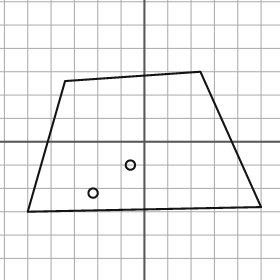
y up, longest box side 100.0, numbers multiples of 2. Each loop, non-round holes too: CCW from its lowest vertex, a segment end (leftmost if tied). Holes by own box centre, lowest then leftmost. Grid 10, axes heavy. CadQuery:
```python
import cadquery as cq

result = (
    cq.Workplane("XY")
    .moveTo(-50.0, -30.0)
    .lineTo(50.0, -28.0)
    .lineTo(24.0, 30.0)
    .lineTo(-34.0, 26.0)
    .close()
    .moveTo(-22.0, -22.0)
    .circle(2.0)
    .moveTo(-6.0, -10.0)
    .circle(2.0)
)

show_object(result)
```